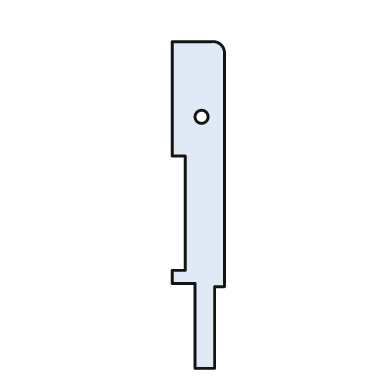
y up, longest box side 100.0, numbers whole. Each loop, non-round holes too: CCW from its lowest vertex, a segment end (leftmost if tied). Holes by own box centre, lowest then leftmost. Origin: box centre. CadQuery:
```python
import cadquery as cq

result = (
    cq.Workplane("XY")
    .moveTo(-1.0, -50.0)
    .lineTo(5.0, -50.0)
    .lineTo(5.0, -25.0)
    .lineTo(8.0, -25.0)
    .lineTo(8.0, 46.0)
    .threePointArc((7.0, 49.0), (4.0, 50.0))
    .lineTo(-8.0, 50.0)
    .lineTo(-8.0, 15.0)
    .lineTo(-4.0, 15.0)
    .lineTo(-4.0, -20.0)
    .lineTo(-8.0, -20.0)
    .lineTo(-8.0, -24.0)
    .lineTo(-1.0, -24.0)
    .close()
    .moveTo(1.0, 27.0)
    .circle(2.0)
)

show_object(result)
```